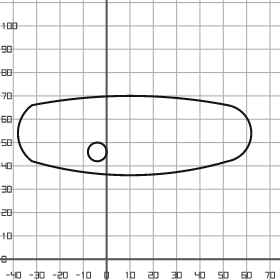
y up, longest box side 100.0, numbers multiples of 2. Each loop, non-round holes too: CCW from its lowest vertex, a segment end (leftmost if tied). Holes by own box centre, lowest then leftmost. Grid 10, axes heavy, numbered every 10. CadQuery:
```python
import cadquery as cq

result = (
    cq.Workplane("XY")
    .moveTo(-32.0, 42.0)
    .threePointArc((10.0, 36.0), (52.0, 42.0))
    .threePointArc((62.0, 54.0), (52.0, 66.0))
    .threePointArc((10.0, 70.0), (-32.0, 66.0))
    .threePointArc((-38.0, 54.0), (-32.0, 42.0))
    .close()
    .moveTo(-4.0, 46.0)
    .circle(4.0)
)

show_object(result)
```